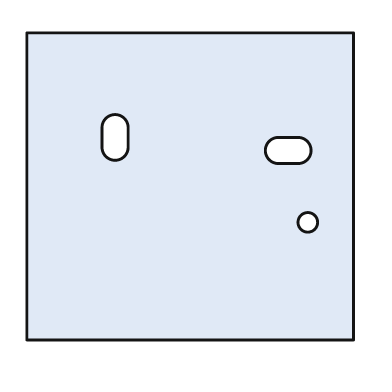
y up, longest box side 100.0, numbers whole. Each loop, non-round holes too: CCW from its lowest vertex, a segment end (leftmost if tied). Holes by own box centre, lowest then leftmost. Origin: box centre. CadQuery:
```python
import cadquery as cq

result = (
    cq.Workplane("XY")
    .moveTo(-50.0, -47.0)
    .lineTo(50.0, -47.0)
    .lineTo(50.0, 47.0)
    .lineTo(-50.0, 47.0)
    .close()
    .moveTo(36.0, -11.0)
    .circle(3.0)
    .moveTo(27.0, 7.0)
    .lineTo(33.0, 7.0)
    .threePointArc((37.0, 11.0), (33.0, 15.0))
    .lineTo(27.0, 15.0)
    .threePointArc((23.0, 11.0), (27.0, 7.0))
    .close()
    .moveTo(-27.0, 12.0)
    .threePointArc((-23.0, 8.0), (-19.0, 12.0))
    .lineTo(-19.0, 18.0)
    .threePointArc((-23.0, 22.0), (-27.0, 18.0))
    .close()
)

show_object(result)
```